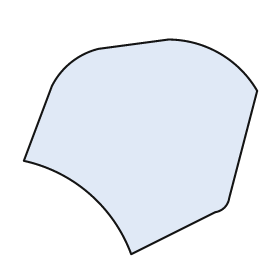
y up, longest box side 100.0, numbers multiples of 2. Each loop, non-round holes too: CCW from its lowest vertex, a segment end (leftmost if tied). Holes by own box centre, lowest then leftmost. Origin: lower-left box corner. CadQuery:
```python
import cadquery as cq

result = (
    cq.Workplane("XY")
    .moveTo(46.0, 0.0)
    .lineTo(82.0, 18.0)
    .threePointArc((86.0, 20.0), (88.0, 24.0))
    .lineTo(100.0, 70.0)
    .threePointArc((84.0, 86.0), (62.0, 92.0))
    .lineTo(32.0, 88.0)
    .threePointArc((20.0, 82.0), (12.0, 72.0))
    .lineTo(0.0, 40.0)
    .threePointArc((28.0, 26.0), (46.0, 0.0))
    .close()
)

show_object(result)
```